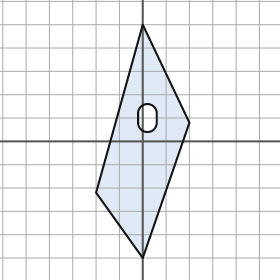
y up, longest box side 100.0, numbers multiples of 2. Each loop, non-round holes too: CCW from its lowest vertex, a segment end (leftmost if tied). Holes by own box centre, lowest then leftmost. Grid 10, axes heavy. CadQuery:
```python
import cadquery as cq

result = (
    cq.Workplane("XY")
    .moveTo(0.0, -50.0)
    .lineTo(20.0, 8.0)
    .lineTo(0.0, 50.0)
    .lineTo(-20.0, -22.0)
    .close()
    .moveTo(-2.0, 8.0)
    .threePointArc((2.0, 4.0), (6.0, 8.0))
    .lineTo(6.0, 12.0)
    .threePointArc((2.0, 16.0), (-2.0, 12.0))
    .close()
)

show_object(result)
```